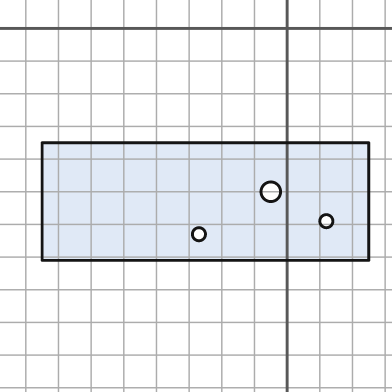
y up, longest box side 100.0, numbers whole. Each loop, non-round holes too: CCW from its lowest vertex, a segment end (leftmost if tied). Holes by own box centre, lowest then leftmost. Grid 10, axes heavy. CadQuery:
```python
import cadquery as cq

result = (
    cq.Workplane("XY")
    .moveTo(-75.0, -71.0)
    .lineTo(25.0, -71.0)
    .lineTo(25.0, -35.0)
    .lineTo(-75.0, -35.0)
    .close()
    .moveTo(-27.0, -63.0)
    .circle(2.0)
    .moveTo(12.0, -59.0)
    .circle(2.0)
    .moveTo(-5.0, -50.0)
    .circle(3.0)
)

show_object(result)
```